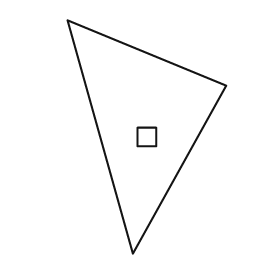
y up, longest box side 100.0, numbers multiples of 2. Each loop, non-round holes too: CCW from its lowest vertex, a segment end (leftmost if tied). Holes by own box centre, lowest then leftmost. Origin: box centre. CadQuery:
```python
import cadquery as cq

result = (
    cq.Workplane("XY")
    .moveTo(-6.0, -50.0)
    .lineTo(34.0, 22.0)
    .lineTo(-34.0, 50.0)
    .close()
    .moveTo(-4.0, -4.0)
    .lineTo(4.0, -4.0)
    .lineTo(4.0, 4.0)
    .lineTo(-4.0, 4.0)
    .close()
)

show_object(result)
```